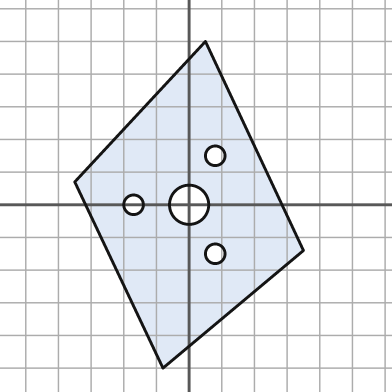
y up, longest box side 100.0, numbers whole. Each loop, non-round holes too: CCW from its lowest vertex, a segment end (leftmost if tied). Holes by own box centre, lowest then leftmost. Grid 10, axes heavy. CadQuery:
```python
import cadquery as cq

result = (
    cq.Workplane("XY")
    .moveTo(-8.0, -50.0)
    .lineTo(35.0, -14.0)
    .lineTo(5.0, 50.0)
    .lineTo(-35.0, 7.0)
    .close()
    .moveTo(8.0, -15.0)
    .circle(3.0)
    .moveTo(-17.0, 0.0)
    .circle(3.0)
    .moveTo(0.0, 0.0)
    .circle(6.0)
    .moveTo(8.0, 15.0)
    .circle(3.0)
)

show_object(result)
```